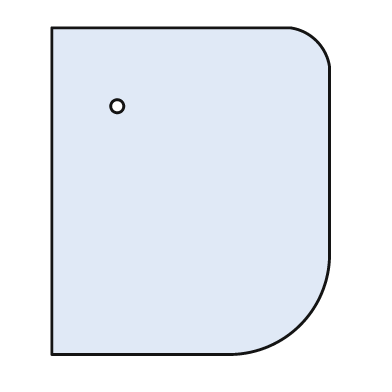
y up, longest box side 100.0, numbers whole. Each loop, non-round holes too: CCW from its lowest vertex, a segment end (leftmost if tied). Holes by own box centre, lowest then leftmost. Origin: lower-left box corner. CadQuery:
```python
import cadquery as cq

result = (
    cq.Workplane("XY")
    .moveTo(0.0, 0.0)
    .lineTo(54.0, 0.0)
    .threePointArc((76.0, 9.0), (85.0, 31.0))
    .lineTo(85.0, 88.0)
    .threePointArc((81.0, 96.0), (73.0, 100.0))
    .lineTo(0.0, 100.0)
    .close()
    .moveTo(20.0, 76.0)
    .circle(2.0)
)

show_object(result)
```